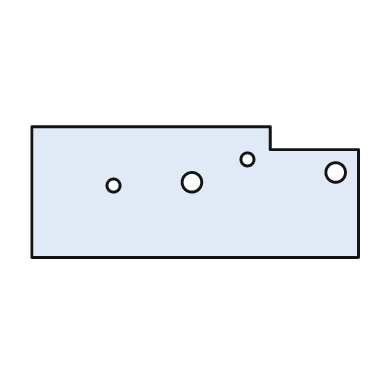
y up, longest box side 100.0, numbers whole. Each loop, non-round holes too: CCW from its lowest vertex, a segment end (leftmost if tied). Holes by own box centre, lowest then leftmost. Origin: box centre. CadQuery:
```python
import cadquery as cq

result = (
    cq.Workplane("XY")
    .moveTo(-50.0, -20.0)
    .lineTo(50.0, -20.0)
    .lineTo(50.0, 13.0)
    .lineTo(23.0, 13.0)
    .lineTo(23.0, 20.0)
    .lineTo(-50.0, 20.0)
    .close()
    .moveTo(-25.0, 2.0)
    .circle(2.0)
    .moveTo(-1.0, 3.0)
    .circle(3.0)
    .moveTo(43.0, 6.0)
    .circle(3.0)
    .moveTo(16.0, 10.0)
    .circle(2.0)
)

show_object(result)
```